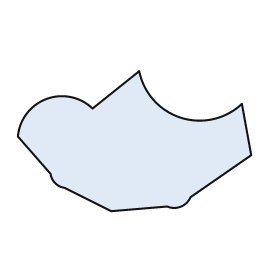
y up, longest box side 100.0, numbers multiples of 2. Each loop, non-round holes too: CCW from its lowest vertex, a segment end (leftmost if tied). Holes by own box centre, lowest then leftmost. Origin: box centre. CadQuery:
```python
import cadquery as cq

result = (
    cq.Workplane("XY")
    .moveTo(-10.0, -30.0)
    .lineTo(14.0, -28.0)
    .threePointArc((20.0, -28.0), (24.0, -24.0))
    .lineTo(50.0, -6.0)
    .lineTo(46.0, 16.0)
    .threePointArc((20.0, 10.0), (2.0, 30.0))
    .lineTo(-18.0, 14.0)
    .threePointArc((-38.0, 18.0), (-50.0, 2.0))
    .lineTo(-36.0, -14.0)
    .threePointArc((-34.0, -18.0), (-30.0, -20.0))
    .close()
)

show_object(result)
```